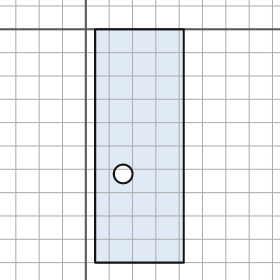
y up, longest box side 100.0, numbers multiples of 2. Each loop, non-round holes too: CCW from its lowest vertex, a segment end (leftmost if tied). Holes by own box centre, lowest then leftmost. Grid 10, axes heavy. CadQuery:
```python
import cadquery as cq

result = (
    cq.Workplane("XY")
    .moveTo(4.0, -100.0)
    .lineTo(42.0, -100.0)
    .lineTo(42.0, 0.0)
    .lineTo(4.0, 0.0)
    .close()
    .moveTo(16.0, -62.0)
    .circle(4.0)
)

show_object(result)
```